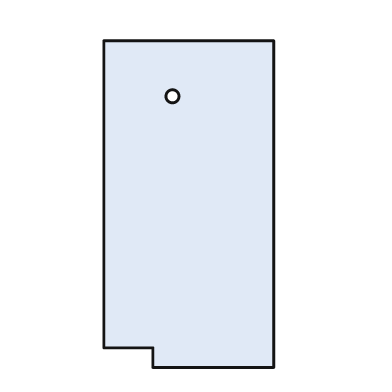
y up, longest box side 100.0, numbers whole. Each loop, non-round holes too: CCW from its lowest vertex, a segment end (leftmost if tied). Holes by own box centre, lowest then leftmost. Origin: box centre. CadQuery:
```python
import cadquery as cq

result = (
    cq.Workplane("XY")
    .moveTo(-11.0, -50.0)
    .lineTo(26.0, -50.0)
    .lineTo(26.0, 50.0)
    .lineTo(-26.0, 50.0)
    .lineTo(-26.0, -44.0)
    .lineTo(-11.0, -44.0)
    .close()
    .moveTo(-5.0, 33.0)
    .circle(2.0)
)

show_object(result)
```